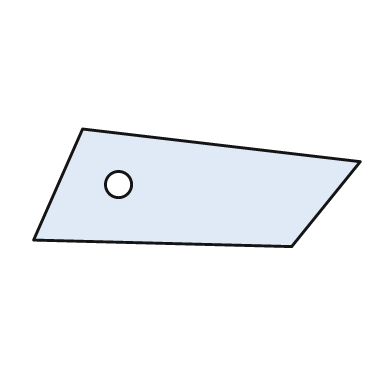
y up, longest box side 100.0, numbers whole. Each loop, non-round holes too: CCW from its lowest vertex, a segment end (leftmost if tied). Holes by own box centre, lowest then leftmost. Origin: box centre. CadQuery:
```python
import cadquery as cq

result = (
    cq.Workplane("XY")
    .moveTo(29.0, -18.0)
    .lineTo(50.0, 8.0)
    .lineTo(-35.0, 18.0)
    .lineTo(-50.0, -16.0)
    .close()
    .moveTo(-24.0, 1.0)
    .circle(4.0)
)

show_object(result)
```